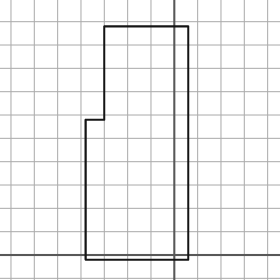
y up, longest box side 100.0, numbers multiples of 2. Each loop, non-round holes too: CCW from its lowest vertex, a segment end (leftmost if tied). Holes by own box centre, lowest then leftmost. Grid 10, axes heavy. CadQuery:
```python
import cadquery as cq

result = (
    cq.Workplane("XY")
    .moveTo(-38.0, -2.0)
    .lineTo(6.0, -2.0)
    .lineTo(6.0, 98.0)
    .lineTo(-30.0, 98.0)
    .lineTo(-30.0, 58.0)
    .lineTo(-38.0, 58.0)
    .close()
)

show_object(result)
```